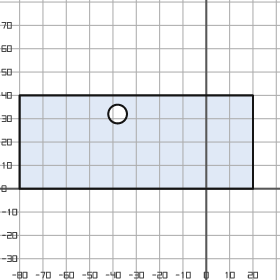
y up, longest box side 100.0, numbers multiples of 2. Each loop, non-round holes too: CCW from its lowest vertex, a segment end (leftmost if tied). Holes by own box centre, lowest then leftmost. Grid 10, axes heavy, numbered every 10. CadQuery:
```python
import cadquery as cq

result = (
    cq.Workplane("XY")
    .moveTo(-80.0, 0.0)
    .lineTo(20.0, 0.0)
    .lineTo(20.0, 40.0)
    .lineTo(-80.0, 40.0)
    .close()
    .moveTo(-38.0, 32.0)
    .circle(4.0)
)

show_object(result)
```